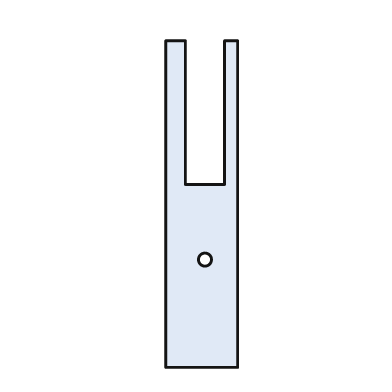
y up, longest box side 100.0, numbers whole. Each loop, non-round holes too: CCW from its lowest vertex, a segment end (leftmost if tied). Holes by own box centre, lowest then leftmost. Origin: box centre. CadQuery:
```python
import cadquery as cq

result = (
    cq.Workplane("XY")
    .moveTo(-11.0, -50.0)
    .lineTo(11.0, -50.0)
    .lineTo(11.0, 50.0)
    .lineTo(7.0, 50.0)
    .lineTo(7.0, 6.0)
    .lineTo(-5.0, 6.0)
    .lineTo(-5.0, 50.0)
    .lineTo(-11.0, 50.0)
    .close()
    .moveTo(1.0, -17.0)
    .circle(2.0)
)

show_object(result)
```